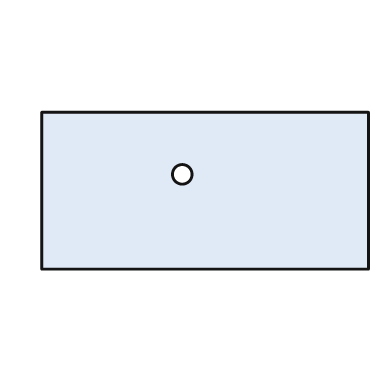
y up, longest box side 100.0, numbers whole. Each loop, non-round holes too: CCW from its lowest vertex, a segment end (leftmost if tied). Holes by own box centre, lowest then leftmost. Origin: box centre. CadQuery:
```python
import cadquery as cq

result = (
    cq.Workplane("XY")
    .moveTo(-50.0, -24.0)
    .lineTo(50.0, -24.0)
    .lineTo(50.0, 24.0)
    .lineTo(-50.0, 24.0)
    .close()
    .moveTo(-7.0, 5.0)
    .circle(3.0)
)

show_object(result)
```